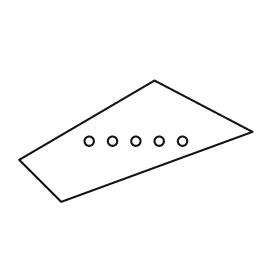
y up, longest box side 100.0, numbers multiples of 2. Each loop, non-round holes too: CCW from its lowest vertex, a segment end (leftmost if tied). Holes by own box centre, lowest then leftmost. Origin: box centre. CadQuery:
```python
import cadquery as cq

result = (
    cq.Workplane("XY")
    .moveTo(-32.0, -26.0)
    .lineTo(50.0, 4.0)
    .lineTo(8.0, 26.0)
    .lineTo(-50.0, -8.0)
    .close()
    .moveTo(-20.0, 0.0)
    .circle(2.0)
    .moveTo(-10.0, 0.0)
    .circle(2.0)
    .moveTo(0.0, 0.0)
    .circle(2.0)
    .moveTo(10.0, 0.0)
    .circle(2.0)
    .moveTo(20.0, 0.0)
    .circle(2.0)
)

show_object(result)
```